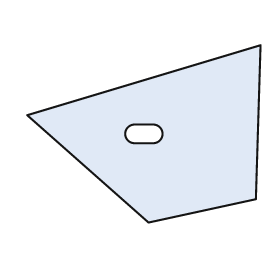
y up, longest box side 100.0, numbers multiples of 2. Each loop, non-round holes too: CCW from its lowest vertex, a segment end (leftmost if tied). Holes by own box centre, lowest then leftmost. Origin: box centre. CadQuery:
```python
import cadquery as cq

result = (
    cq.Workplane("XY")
    .moveTo(2.0, -38.0)
    .lineTo(48.0, -28.0)
    .lineTo(50.0, 38.0)
    .lineTo(-50.0, 8.0)
    .close()
    .moveTo(-4.0, -4.0)
    .lineTo(4.0, -4.0)
    .threePointArc((8.0, 0.0), (4.0, 4.0))
    .lineTo(-4.0, 4.0)
    .threePointArc((-8.0, 0.0), (-4.0, -4.0))
    .close()
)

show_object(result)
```